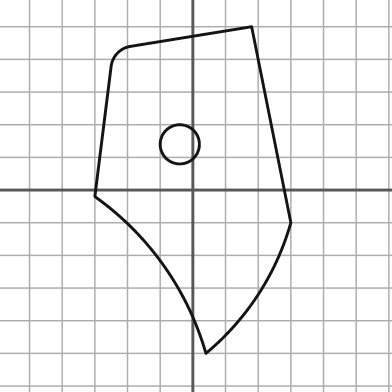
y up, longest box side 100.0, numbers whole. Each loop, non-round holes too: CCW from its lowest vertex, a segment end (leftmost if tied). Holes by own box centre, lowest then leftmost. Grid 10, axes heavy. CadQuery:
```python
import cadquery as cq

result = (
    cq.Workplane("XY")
    .moveTo(4.0, -50.0)
    .threePointArc((20.0, -32.0), (30.0, -10.0))
    .lineTo(18.0, 50.0)
    .lineTo(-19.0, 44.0)
    .threePointArc((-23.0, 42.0), (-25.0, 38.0))
    .lineTo(-30.0, -2.0)
    .threePointArc((-9.0, -23.0), (4.0, -50.0))
    .close()
    .moveTo(-4.0, 14.0)
    .circle(6.0)
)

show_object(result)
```